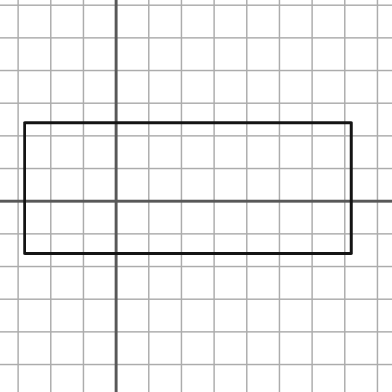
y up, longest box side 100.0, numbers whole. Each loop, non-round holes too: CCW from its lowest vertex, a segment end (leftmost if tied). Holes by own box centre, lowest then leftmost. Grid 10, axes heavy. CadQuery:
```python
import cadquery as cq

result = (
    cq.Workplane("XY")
    .moveTo(-28.0, -16.0)
    .lineTo(72.0, -16.0)
    .lineTo(72.0, 24.0)
    .lineTo(-28.0, 24.0)
    .close()
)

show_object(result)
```